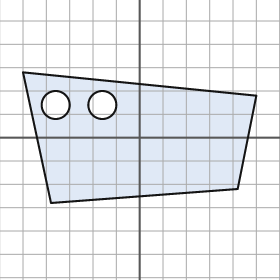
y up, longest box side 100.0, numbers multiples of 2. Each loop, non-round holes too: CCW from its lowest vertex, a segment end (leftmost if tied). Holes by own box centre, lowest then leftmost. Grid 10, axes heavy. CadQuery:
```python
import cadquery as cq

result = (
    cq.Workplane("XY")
    .moveTo(-38.0, -28.0)
    .lineTo(42.0, -22.0)
    .lineTo(50.0, 18.0)
    .lineTo(-50.0, 28.0)
    .close()
    .moveTo(-36.0, 14.0)
    .circle(6.0)
    .moveTo(-16.0, 14.0)
    .circle(6.0)
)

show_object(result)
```